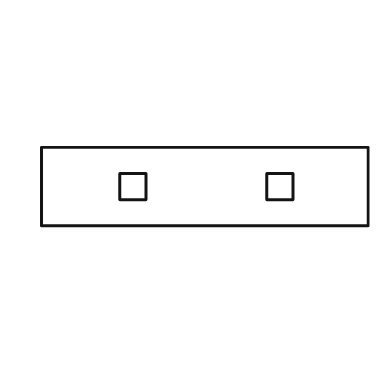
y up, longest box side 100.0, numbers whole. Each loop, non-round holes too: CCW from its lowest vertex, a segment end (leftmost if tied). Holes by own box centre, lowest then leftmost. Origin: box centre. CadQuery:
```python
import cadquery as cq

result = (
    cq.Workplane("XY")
    .moveTo(-50.0, -12.0)
    .lineTo(50.0, -12.0)
    .lineTo(50.0, 12.0)
    .lineTo(-50.0, 12.0)
    .close()
    .moveTo(-26.0, -4.0)
    .lineTo(-18.0, -4.0)
    .lineTo(-18.0, 4.0)
    .lineTo(-26.0, 4.0)
    .close()
    .moveTo(19.0, -4.0)
    .lineTo(27.0, -4.0)
    .lineTo(27.0, 4.0)
    .lineTo(19.0, 4.0)
    .close()
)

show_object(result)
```